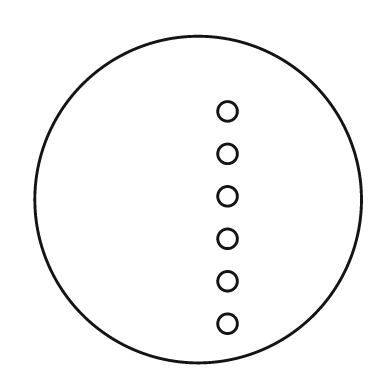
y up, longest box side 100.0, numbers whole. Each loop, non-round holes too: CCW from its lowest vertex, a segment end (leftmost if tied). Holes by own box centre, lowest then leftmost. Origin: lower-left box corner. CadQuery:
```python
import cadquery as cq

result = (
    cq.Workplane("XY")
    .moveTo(50.0, 50.0)
    .circle(50.0)
    .moveTo(59.0, 12.0)
    .circle(3.0)
    .moveTo(59.0, 25.0)
    .circle(3.0)
    .moveTo(59.0, 38.0)
    .circle(3.0)
    .moveTo(59.0, 51.0)
    .circle(3.0)
    .moveTo(59.0, 64.0)
    .circle(3.0)
    .moveTo(59.0, 77.0)
    .circle(3.0)
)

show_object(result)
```